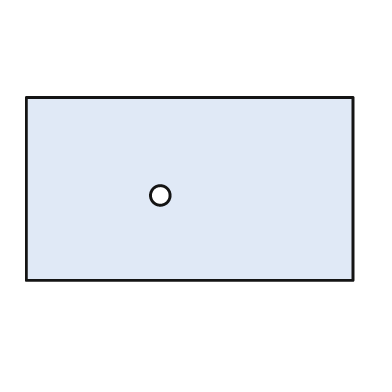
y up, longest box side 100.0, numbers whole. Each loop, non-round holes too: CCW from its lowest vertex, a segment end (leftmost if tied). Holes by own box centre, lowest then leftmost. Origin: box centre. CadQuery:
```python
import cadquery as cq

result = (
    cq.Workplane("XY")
    .moveTo(-50.0, -28.0)
    .lineTo(50.0, -28.0)
    .lineTo(50.0, 28.0)
    .lineTo(-50.0, 28.0)
    .close()
    .moveTo(-9.0, -2.0)
    .circle(3.0)
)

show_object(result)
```